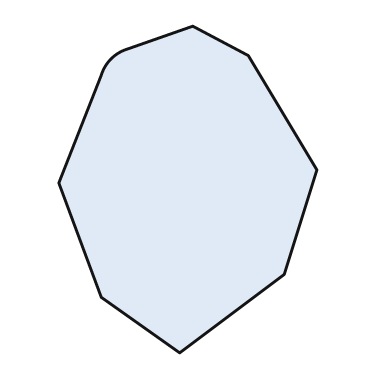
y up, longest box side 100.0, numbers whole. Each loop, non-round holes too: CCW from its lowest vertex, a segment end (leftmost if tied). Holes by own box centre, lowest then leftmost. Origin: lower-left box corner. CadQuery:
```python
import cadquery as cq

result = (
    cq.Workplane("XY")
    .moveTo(37.0, 0.0)
    .lineTo(69.0, 24.0)
    .lineTo(79.0, 56.0)
    .lineTo(58.0, 91.0)
    .lineTo(41.0, 100.0)
    .lineTo(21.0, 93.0)
    .threePointArc((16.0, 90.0), (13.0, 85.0))
    .lineTo(0.0, 52.0)
    .lineTo(13.0, 17.0)
    .close()
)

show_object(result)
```